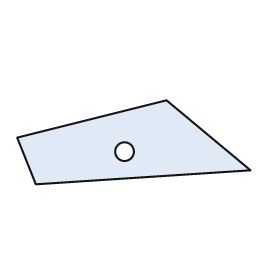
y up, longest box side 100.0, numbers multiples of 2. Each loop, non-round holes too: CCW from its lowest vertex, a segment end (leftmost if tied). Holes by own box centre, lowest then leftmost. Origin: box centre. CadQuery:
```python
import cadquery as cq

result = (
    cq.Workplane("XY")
    .moveTo(-42.0, -18.0)
    .lineTo(50.0, -12.0)
    .lineTo(14.0, 18.0)
    .lineTo(-50.0, 2.0)
    .close()
    .moveTo(-4.0, -4.0)
    .circle(4.0)
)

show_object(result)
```